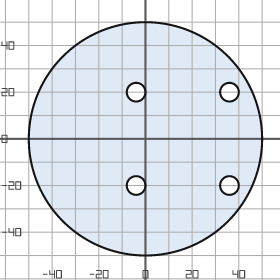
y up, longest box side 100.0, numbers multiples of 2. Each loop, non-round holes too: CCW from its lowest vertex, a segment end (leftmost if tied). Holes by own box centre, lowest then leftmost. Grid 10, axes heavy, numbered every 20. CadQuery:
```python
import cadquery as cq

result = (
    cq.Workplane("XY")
    .moveTo(0.0, 0.0)
    .circle(50.0)
    .moveTo(-4.0, -20.0)
    .circle(4.0)
    .moveTo(36.0, -20.0)
    .circle(4.0)
    .moveTo(-4.0, 20.0)
    .circle(4.0)
    .moveTo(36.0, 20.0)
    .circle(4.0)
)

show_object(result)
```